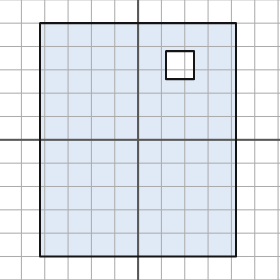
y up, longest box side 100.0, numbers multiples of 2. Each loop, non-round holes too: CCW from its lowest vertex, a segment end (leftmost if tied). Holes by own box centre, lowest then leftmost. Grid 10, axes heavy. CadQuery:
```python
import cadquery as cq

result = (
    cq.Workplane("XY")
    .moveTo(-42.0, -50.0)
    .lineTo(42.0, -50.0)
    .lineTo(42.0, 50.0)
    .lineTo(-42.0, 50.0)
    .close()
    .moveTo(12.0, 26.0)
    .lineTo(24.0, 26.0)
    .lineTo(24.0, 38.0)
    .lineTo(12.0, 38.0)
    .close()
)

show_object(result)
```